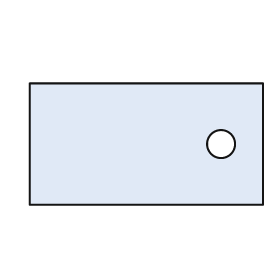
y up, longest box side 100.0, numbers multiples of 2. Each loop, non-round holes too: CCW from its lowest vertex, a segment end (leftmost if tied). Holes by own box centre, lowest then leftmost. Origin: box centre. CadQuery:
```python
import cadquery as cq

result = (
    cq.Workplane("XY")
    .moveTo(-50.0, -26.0)
    .lineTo(50.0, -26.0)
    .lineTo(50.0, 26.0)
    .lineTo(-50.0, 26.0)
    .close()
    .moveTo(32.0, 0.0)
    .circle(6.0)
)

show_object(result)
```